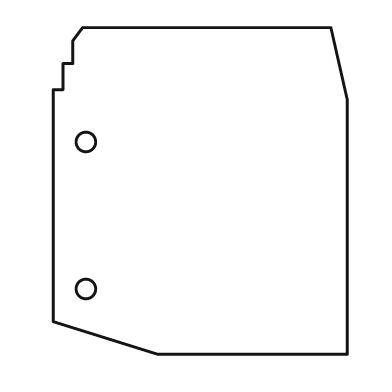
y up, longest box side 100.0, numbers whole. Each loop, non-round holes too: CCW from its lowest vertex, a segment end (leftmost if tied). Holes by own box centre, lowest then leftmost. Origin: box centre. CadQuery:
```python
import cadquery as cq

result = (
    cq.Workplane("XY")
    .moveTo(-13.0, -50.0)
    .lineTo(45.0, -50.0)
    .lineTo(45.0, 28.0)
    .lineTo(40.0, 50.0)
    .lineTo(-36.0, 50.0)
    .lineTo(-39.0, 46.0)
    .lineTo(-39.0, 39.0)
    .lineTo(-42.0, 39.0)
    .lineTo(-42.0, 31.0)
    .lineTo(-45.0, 31.0)
    .lineTo(-45.0, -40.0)
    .close()
    .moveTo(-35.0, -30.0)
    .circle(3.0)
    .moveTo(-35.0, 15.0)
    .circle(3.0)
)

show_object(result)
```